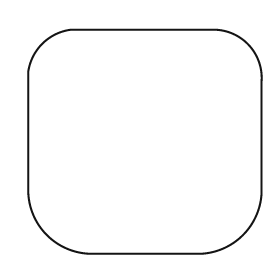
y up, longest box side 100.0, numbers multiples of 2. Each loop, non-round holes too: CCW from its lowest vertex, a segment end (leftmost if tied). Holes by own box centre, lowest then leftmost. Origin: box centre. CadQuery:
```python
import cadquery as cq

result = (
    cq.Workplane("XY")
    .moveTo(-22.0, -48.0)
    .lineTo(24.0, -48.0)
    .threePointArc((42.0, -40.0), (50.0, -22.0))
    .lineTo(50.0, 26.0)
    .threePointArc((44.0, 42.0), (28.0, 48.0))
    .lineTo(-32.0, 48.0)
    .threePointArc((-44.0, 42.0), (-50.0, 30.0))
    .lineTo(-50.0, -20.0)
    .threePointArc((-42.0, -40.0), (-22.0, -48.0))
    .close()
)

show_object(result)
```